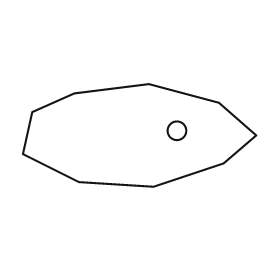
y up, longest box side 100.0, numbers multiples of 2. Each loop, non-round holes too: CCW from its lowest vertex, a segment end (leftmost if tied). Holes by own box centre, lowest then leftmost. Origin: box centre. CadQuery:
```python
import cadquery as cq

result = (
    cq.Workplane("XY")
    .moveTo(6.0, -22.0)
    .lineTo(36.0, -12.0)
    .lineTo(50.0, 0.0)
    .lineTo(34.0, 14.0)
    .lineTo(4.0, 22.0)
    .lineTo(-28.0, 18.0)
    .lineTo(-46.0, 10.0)
    .lineTo(-50.0, -8.0)
    .lineTo(-26.0, -20.0)
    .close()
    .moveTo(16.0, 2.0)
    .circle(4.0)
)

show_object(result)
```